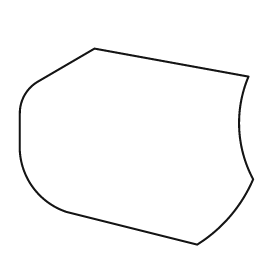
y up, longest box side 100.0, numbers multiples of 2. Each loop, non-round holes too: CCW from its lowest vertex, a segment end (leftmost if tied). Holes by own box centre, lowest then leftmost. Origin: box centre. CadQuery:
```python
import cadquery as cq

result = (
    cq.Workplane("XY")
    .moveTo(26.0, -42.0)
    .threePointArc((40.0, -30.0), (50.0, -14.0))
    .threePointArc((44.0, 8.0), (48.0, 30.0))
    .lineTo(-18.0, 42.0)
    .lineTo(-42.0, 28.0)
    .threePointArc((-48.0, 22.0), (-50.0, 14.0))
    .lineTo(-50.0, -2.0)
    .threePointArc((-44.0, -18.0), (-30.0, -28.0))
    .close()
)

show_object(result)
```